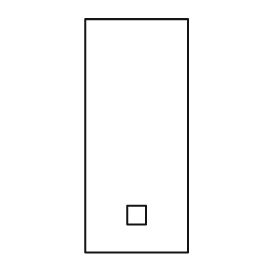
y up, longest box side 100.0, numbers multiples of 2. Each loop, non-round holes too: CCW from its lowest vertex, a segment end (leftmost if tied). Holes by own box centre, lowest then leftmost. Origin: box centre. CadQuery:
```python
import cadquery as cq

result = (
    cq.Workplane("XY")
    .moveTo(-22.0, -50.0)
    .lineTo(22.0, -50.0)
    .lineTo(22.0, 50.0)
    .lineTo(-22.0, 50.0)
    .close()
    .moveTo(-4.0, -38.0)
    .lineTo(4.0, -38.0)
    .lineTo(4.0, -30.0)
    .lineTo(-4.0, -30.0)
    .close()
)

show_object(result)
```